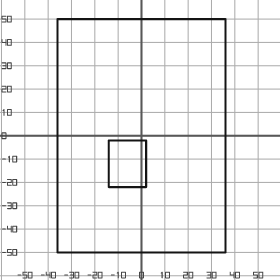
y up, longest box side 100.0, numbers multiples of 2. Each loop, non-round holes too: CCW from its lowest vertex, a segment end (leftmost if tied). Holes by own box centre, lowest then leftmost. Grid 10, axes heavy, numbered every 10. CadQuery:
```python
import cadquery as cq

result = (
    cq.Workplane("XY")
    .moveTo(-36.0, -50.0)
    .lineTo(36.0, -50.0)
    .lineTo(36.0, 50.0)
    .lineTo(-36.0, 50.0)
    .close()
    .moveTo(-14.0, -22.0)
    .lineTo(2.0, -22.0)
    .lineTo(2.0, -2.0)
    .lineTo(-14.0, -2.0)
    .close()
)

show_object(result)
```